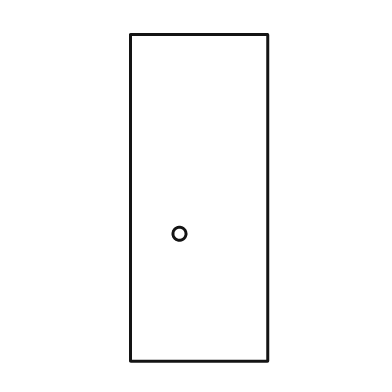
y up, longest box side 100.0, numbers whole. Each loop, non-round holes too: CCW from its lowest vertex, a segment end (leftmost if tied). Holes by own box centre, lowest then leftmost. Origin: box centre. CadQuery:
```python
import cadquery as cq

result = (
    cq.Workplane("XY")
    .moveTo(-21.0, -50.0)
    .lineTo(21.0, -50.0)
    .lineTo(21.0, 50.0)
    .lineTo(-21.0, 50.0)
    .close()
    .moveTo(-6.0, -11.0)
    .circle(2.0)
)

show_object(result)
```